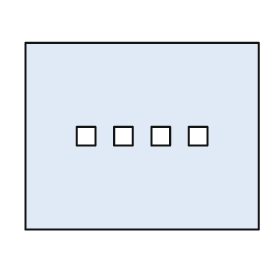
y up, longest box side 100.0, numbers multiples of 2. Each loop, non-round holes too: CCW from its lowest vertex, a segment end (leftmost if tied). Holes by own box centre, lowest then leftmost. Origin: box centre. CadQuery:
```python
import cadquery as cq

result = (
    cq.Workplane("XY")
    .moveTo(-50.0, -40.0)
    .lineTo(50.0, -40.0)
    .lineTo(50.0, 40.0)
    .lineTo(-50.0, 40.0)
    .close()
    .moveTo(-28.0, -4.0)
    .lineTo(-20.0, -4.0)
    .lineTo(-20.0, 4.0)
    .lineTo(-28.0, 4.0)
    .close()
    .moveTo(-12.0, -4.0)
    .lineTo(-4.0, -4.0)
    .lineTo(-4.0, 4.0)
    .lineTo(-12.0, 4.0)
    .close()
    .moveTo(4.0, -4.0)
    .lineTo(12.0, -4.0)
    .lineTo(12.0, 4.0)
    .lineTo(4.0, 4.0)
    .close()
    .moveTo(20.0, -4.0)
    .lineTo(28.0, -4.0)
    .lineTo(28.0, 4.0)
    .lineTo(20.0, 4.0)
    .close()
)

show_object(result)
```